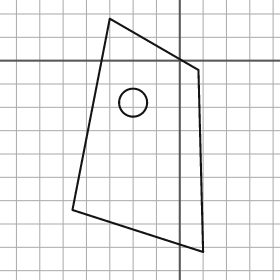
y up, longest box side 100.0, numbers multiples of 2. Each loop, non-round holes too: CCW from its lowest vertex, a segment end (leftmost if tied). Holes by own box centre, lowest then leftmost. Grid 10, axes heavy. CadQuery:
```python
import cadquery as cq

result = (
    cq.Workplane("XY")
    .moveTo(10.0, -82.0)
    .lineTo(8.0, -4.0)
    .lineTo(-30.0, 18.0)
    .lineTo(-46.0, -64.0)
    .close()
    .moveTo(-20.0, -18.0)
    .circle(6.0)
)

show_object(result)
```